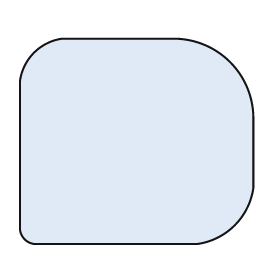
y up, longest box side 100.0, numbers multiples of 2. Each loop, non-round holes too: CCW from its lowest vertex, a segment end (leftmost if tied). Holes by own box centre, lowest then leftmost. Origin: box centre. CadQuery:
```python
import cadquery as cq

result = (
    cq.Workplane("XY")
    .moveTo(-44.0, -44.0)
    .lineTo(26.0, -44.0)
    .threePointArc((42.0, -36.0), (50.0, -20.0))
    .lineTo(50.0, 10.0)
    .threePointArc((40.0, 34.0), (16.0, 44.0))
    .lineTo(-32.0, 44.0)
    .threePointArc((-44.0, 38.0), (-50.0, 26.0))
    .lineTo(-50.0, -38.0)
    .threePointArc((-48.0, -42.0), (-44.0, -44.0))
    .close()
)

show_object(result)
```